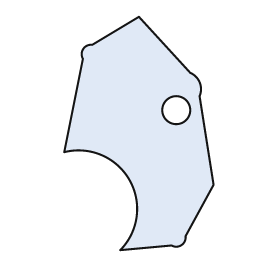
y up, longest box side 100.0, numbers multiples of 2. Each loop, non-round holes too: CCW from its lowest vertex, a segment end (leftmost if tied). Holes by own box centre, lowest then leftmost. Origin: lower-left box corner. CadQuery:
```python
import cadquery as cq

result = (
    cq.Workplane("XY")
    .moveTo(24.0, 0.0)
    .lineTo(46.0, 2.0)
    .threePointArc((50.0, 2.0), (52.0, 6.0))
    .lineTo(64.0, 28.0)
    .lineTo(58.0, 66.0)
    .threePointArc((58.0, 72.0), (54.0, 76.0))
    .lineTo(32.0, 100.0)
    .lineTo(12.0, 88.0)
    .threePointArc((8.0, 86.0), (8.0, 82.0))
    .lineTo(0.0, 42.0)
    .threePointArc((28.0, 30.0), (24.0, 0.0))
    .close()
    .moveTo(48.0, 60.0)
    .circle(6.0)
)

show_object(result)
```